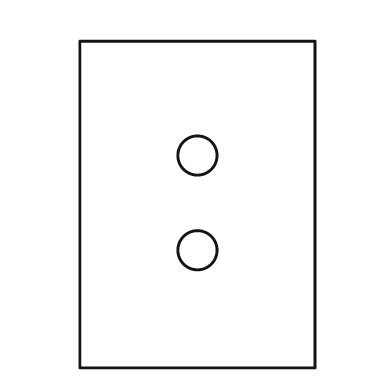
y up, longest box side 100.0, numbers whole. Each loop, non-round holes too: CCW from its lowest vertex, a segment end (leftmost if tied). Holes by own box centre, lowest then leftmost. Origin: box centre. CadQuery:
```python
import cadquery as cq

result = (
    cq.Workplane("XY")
    .moveTo(-36.0, -50.0)
    .lineTo(36.0, -50.0)
    .lineTo(36.0, 50.0)
    .lineTo(-36.0, 50.0)
    .close()
    .moveTo(0.0, -14.0)
    .circle(6.0)
    .moveTo(0.0, 15.0)
    .circle(6.0)
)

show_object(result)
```